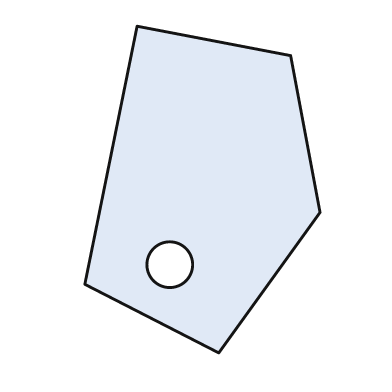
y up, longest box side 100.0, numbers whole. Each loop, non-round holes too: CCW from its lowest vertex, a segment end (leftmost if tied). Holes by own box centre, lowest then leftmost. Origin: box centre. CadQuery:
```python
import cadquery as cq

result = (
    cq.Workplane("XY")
    .moveTo(5.0, -50.0)
    .lineTo(36.0, -7.0)
    .lineTo(27.0, 41.0)
    .lineTo(-20.0, 50.0)
    .lineTo(-36.0, -29.0)
    .close()
    .moveTo(-10.0, -23.0)
    .circle(7.0)
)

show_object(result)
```